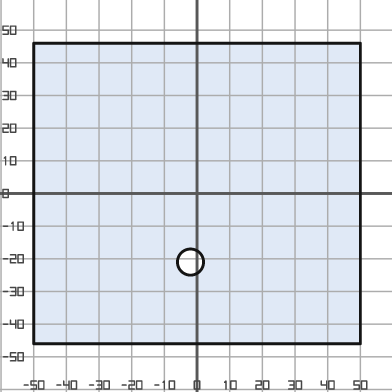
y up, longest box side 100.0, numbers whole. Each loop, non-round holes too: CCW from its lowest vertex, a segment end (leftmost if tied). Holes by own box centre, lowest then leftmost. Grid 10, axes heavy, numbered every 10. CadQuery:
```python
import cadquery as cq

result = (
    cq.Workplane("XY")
    .moveTo(-50.0, -46.0)
    .lineTo(50.0, -46.0)
    .lineTo(50.0, 46.0)
    .lineTo(-50.0, 46.0)
    .close()
    .moveTo(-2.0, -21.0)
    .circle(4.0)
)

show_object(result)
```